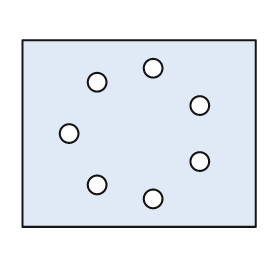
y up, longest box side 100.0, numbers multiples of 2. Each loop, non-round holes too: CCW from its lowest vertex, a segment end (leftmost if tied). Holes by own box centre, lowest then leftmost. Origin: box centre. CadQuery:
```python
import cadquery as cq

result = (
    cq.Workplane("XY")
    .moveTo(-50.0, -40.0)
    .lineTo(50.0, -40.0)
    .lineTo(50.0, 40.0)
    .lineTo(-50.0, 40.0)
    .close()
    .moveTo(6.0, -28.0)
    .circle(4.0)
    .moveTo(-18.0, -22.0)
    .circle(4.0)
    .moveTo(26.0, -12.0)
    .circle(4.0)
    .moveTo(-30.0, 0.0)
    .circle(4.0)
    .moveTo(26.0, 12.0)
    .circle(4.0)
    .moveTo(-18.0, 22.0)
    .circle(4.0)
    .moveTo(6.0, 28.0)
    .circle(4.0)
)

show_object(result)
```